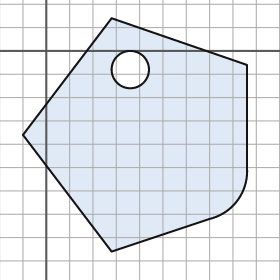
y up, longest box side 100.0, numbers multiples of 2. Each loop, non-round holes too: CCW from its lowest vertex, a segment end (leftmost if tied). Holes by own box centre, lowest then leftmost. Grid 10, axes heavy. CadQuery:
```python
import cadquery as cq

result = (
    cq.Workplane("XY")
    .moveTo(28.0, -86.0)
    .lineTo(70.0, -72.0)
    .threePointArc((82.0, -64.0), (86.0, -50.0))
    .lineTo(86.0, -6.0)
    .lineTo(28.0, 14.0)
    .lineTo(-10.0, -36.0)
    .close()
    .moveTo(36.0, -8.0)
    .circle(8.0)
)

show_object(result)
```